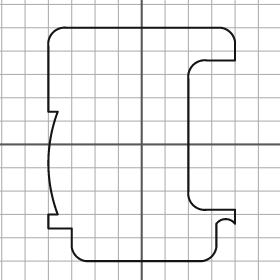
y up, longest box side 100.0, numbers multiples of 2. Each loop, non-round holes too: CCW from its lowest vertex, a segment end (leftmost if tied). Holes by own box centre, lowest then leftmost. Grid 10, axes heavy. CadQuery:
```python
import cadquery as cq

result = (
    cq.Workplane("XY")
    .moveTo(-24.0, -50.0)
    .lineTo(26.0, -50.0)
    .threePointArc((30.0, -48.0), (32.0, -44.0))
    .lineTo(32.0, -34.0)
    .threePointArc((36.0, -32.0), (40.0, -34.0))
    .lineTo(40.0, -28.0)
    .lineTo(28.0, -28.0)
    .threePointArc((22.0, -26.0), (20.0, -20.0))
    .lineTo(20.0, 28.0)
    .threePointArc((22.0, 34.0), (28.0, 36.0))
    .lineTo(40.0, 36.0)
    .lineTo(40.0, 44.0)
    .threePointArc((38.0, 48.0), (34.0, 50.0))
    .lineTo(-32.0, 50.0)
    .threePointArc((-38.0, 48.0), (-40.0, 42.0))
    .lineTo(-40.0, 14.0)
    .lineTo(-36.0, 14.0)
    .threePointArc((-40.0, -8.0), (-36.0, -30.0))
    .lineTo(-40.0, -30.0)
    .lineTo(-40.0, -36.0)
    .lineTo(-30.0, -36.0)
    .lineTo(-30.0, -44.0)
    .threePointArc((-28.0, -48.0), (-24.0, -50.0))
    .close()
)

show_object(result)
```